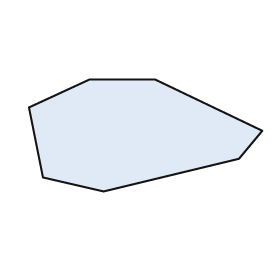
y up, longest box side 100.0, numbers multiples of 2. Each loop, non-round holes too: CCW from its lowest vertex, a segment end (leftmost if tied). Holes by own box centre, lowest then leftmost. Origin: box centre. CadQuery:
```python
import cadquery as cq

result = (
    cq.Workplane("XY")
    .moveTo(-18.0, -24.0)
    .lineTo(40.0, -10.0)
    .lineTo(50.0, 2.0)
    .lineTo(4.0, 24.0)
    .lineTo(-24.0, 24.0)
    .lineTo(-50.0, 12.0)
    .lineTo(-44.0, -18.0)
    .close()
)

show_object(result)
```